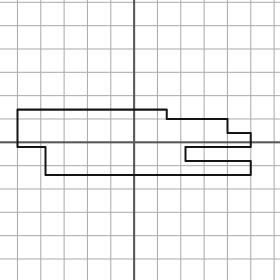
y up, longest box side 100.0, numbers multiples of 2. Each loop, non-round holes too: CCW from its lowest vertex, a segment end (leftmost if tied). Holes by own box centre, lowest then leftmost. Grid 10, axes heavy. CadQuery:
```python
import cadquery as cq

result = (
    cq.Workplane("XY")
    .moveTo(-38.0, -14.0)
    .lineTo(50.0, -14.0)
    .lineTo(50.0, -8.0)
    .lineTo(22.0, -8.0)
    .lineTo(22.0, -2.0)
    .lineTo(50.0, -2.0)
    .lineTo(50.0, 4.0)
    .lineTo(40.0, 4.0)
    .lineTo(40.0, 10.0)
    .lineTo(14.0, 10.0)
    .lineTo(14.0, 14.0)
    .lineTo(-50.0, 14.0)
    .lineTo(-50.0, -2.0)
    .lineTo(-38.0, -2.0)
    .close()
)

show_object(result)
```